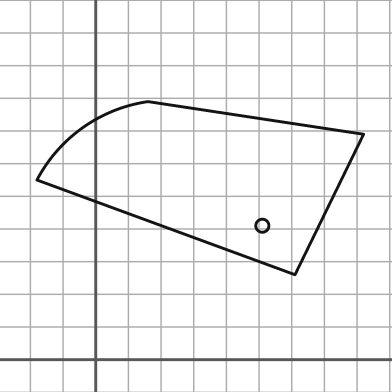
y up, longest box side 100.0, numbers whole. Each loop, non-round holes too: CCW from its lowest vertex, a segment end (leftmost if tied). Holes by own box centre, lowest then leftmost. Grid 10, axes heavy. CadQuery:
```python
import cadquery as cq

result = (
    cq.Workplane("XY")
    .moveTo(61.0, 26.0)
    .lineTo(82.0, 69.0)
    .lineTo(16.0, 79.0)
    .threePointArc((-4.0, 71.0), (-18.0, 55.0))
    .close()
    .moveTo(51.0, 41.0)
    .circle(2.0)
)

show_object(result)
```